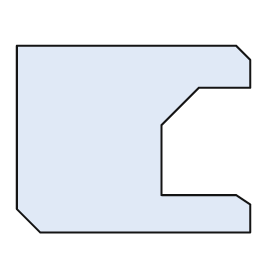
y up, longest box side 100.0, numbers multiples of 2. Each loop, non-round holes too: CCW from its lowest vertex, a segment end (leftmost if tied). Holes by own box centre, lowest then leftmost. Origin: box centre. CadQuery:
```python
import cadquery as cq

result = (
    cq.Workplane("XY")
    .moveTo(-40.0, -40.0)
    .lineTo(50.0, -40.0)
    .lineTo(50.0, -28.0)
    .lineTo(44.0, -24.0)
    .lineTo(12.0, -24.0)
    .lineTo(12.0, 6.0)
    .lineTo(28.0, 22.0)
    .lineTo(50.0, 22.0)
    .lineTo(50.0, 34.0)
    .lineTo(44.0, 40.0)
    .lineTo(-50.0, 40.0)
    .lineTo(-50.0, -30.0)
    .close()
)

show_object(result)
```